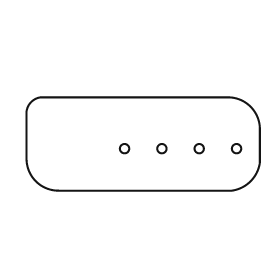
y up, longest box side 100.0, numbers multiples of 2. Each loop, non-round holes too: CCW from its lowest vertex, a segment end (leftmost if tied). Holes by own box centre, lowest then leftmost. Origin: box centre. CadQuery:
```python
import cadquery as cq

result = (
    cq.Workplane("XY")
    .moveTo(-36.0, -20.0)
    .lineTo(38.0, -20.0)
    .threePointArc((46.0, -16.0), (50.0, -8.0))
    .lineTo(50.0, 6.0)
    .threePointArc((46.0, 16.0), (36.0, 20.0))
    .lineTo(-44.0, 20.0)
    .threePointArc((-48.0, 18.0), (-50.0, 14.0))
    .lineTo(-50.0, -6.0)
    .threePointArc((-46.0, -16.0), (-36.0, -20.0))
    .close()
    .moveTo(-8.0, -2.0)
    .circle(2.0)
    .moveTo(8.0, -2.0)
    .circle(2.0)
    .moveTo(24.0, -2.0)
    .circle(2.0)
    .moveTo(40.0, -2.0)
    .circle(2.0)
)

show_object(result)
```